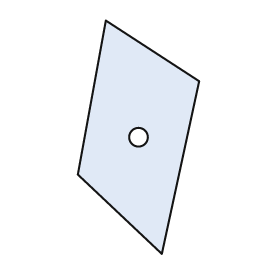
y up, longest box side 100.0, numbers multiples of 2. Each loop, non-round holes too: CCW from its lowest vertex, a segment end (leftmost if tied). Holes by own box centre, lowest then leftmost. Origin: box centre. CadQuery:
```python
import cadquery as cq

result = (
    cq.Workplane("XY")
    .moveTo(10.0, -50.0)
    .lineTo(26.0, 24.0)
    .lineTo(-14.0, 50.0)
    .lineTo(-26.0, -16.0)
    .close()
    .moveTo(0.0, 0.0)
    .circle(4.0)
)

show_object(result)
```